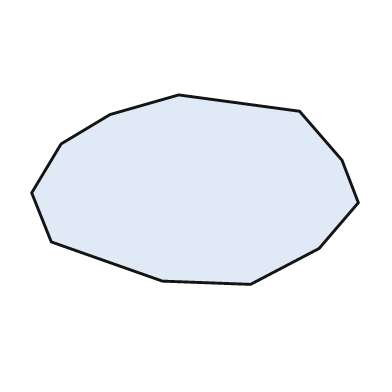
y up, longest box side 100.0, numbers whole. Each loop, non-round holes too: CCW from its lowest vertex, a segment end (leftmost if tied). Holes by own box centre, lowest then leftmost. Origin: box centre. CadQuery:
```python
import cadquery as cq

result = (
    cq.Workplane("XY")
    .moveTo(17.0, -29.0)
    .lineTo(38.0, -18.0)
    .lineTo(50.0, -4.0)
    .lineTo(45.0, 9.0)
    .lineTo(32.0, 24.0)
    .lineTo(-5.0, 29.0)
    .lineTo(-26.0, 23.0)
    .lineTo(-41.0, 14.0)
    .lineTo(-50.0, -1.0)
    .lineTo(-44.0, -16.0)
    .lineTo(-10.0, -28.0)
    .close()
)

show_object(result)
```